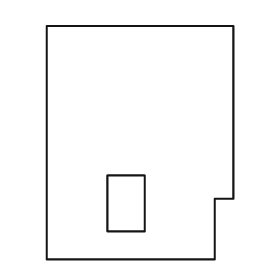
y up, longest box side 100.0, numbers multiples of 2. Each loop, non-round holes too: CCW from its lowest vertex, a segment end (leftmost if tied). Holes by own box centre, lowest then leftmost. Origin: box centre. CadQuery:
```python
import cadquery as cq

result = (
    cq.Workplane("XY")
    .moveTo(-40.0, -50.0)
    .lineTo(32.0, -50.0)
    .lineTo(32.0, -24.0)
    .lineTo(40.0, -24.0)
    .lineTo(40.0, 50.0)
    .lineTo(-40.0, 50.0)
    .close()
    .moveTo(-14.0, -38.0)
    .lineTo(2.0, -38.0)
    .lineTo(2.0, -14.0)
    .lineTo(-14.0, -14.0)
    .close()
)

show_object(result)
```